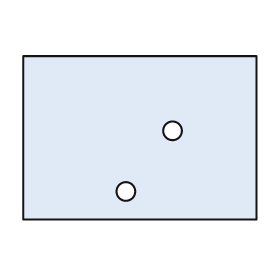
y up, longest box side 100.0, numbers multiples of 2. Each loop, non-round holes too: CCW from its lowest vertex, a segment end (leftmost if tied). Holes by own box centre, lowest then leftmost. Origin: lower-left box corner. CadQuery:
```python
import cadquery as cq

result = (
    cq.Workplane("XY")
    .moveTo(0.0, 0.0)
    .lineTo(100.0, 0.0)
    .lineTo(100.0, 70.0)
    .lineTo(0.0, 70.0)
    .close()
    .moveTo(44.0, 12.0)
    .circle(4.0)
    .moveTo(64.0, 38.0)
    .circle(4.0)
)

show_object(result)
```